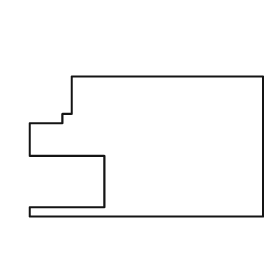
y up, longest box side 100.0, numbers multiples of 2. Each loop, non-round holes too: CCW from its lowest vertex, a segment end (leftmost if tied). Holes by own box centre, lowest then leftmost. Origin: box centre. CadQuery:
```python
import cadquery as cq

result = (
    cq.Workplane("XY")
    .moveTo(-50.0, -30.0)
    .lineTo(50.0, -30.0)
    .lineTo(50.0, 30.0)
    .lineTo(-32.0, 30.0)
    .lineTo(-32.0, 14.0)
    .lineTo(-36.0, 14.0)
    .lineTo(-36.0, 10.0)
    .lineTo(-50.0, 10.0)
    .lineTo(-50.0, -4.0)
    .lineTo(-18.0, -4.0)
    .lineTo(-18.0, -26.0)
    .lineTo(-50.0, -26.0)
    .close()
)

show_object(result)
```